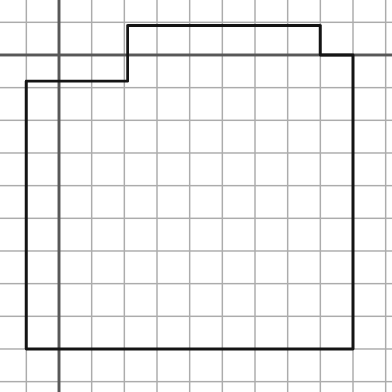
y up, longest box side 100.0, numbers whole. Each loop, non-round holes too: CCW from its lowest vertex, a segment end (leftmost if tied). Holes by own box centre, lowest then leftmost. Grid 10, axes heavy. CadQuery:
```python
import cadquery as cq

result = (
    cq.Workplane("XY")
    .moveTo(-10.0, -90.0)
    .lineTo(90.0, -90.0)
    .lineTo(90.0, 0.0)
    .lineTo(80.0, 0.0)
    .lineTo(80.0, 9.0)
    .lineTo(21.0, 9.0)
    .lineTo(21.0, -8.0)
    .lineTo(-10.0, -8.0)
    .close()
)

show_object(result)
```